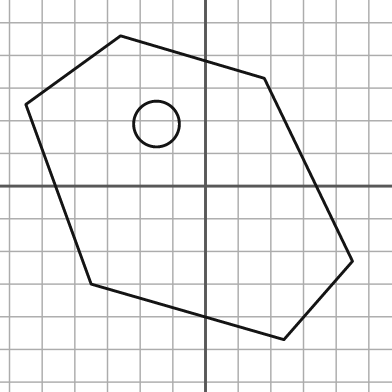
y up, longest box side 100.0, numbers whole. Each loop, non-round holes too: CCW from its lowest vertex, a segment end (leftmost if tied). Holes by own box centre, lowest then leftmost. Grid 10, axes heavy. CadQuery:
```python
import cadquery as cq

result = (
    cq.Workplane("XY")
    .moveTo(24.0, -47.0)
    .lineTo(45.0, -23.0)
    .lineTo(18.0, 33.0)
    .lineTo(-26.0, 46.0)
    .lineTo(-55.0, 25.0)
    .lineTo(-35.0, -30.0)
    .close()
    .moveTo(-15.0, 19.0)
    .circle(7.0)
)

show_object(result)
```